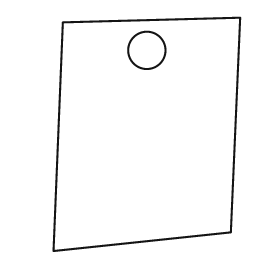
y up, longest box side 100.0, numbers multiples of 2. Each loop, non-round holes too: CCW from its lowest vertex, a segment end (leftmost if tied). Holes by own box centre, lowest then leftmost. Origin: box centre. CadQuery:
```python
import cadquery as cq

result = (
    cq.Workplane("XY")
    .moveTo(-40.0, -50.0)
    .lineTo(36.0, -42.0)
    .lineTo(40.0, 50.0)
    .lineTo(-36.0, 48.0)
    .close()
    .moveTo(0.0, 36.0)
    .circle(8.0)
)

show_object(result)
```